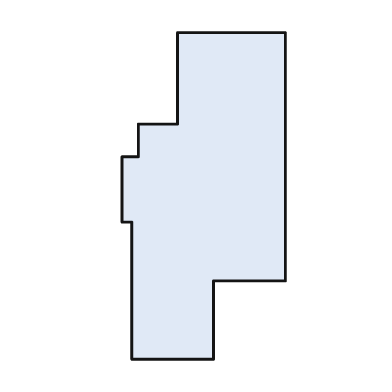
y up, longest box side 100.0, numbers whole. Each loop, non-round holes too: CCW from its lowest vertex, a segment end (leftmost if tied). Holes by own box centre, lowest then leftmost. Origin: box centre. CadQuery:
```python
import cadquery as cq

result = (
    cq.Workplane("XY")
    .moveTo(-22.0, -50.0)
    .lineTo(3.0, -50.0)
    .lineTo(3.0, -26.0)
    .lineTo(25.0, -26.0)
    .lineTo(25.0, 50.0)
    .lineTo(-8.0, 50.0)
    .lineTo(-8.0, 22.0)
    .lineTo(-20.0, 22.0)
    .lineTo(-20.0, 12.0)
    .lineTo(-25.0, 12.0)
    .lineTo(-25.0, -8.0)
    .lineTo(-22.0, -8.0)
    .close()
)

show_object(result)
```